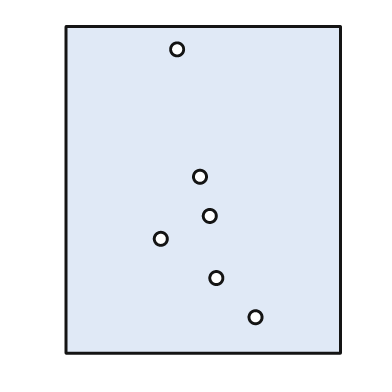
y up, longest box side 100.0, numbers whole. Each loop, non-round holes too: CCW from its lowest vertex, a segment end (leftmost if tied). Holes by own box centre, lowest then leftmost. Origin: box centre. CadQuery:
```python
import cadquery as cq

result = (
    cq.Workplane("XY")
    .moveTo(-42.0, -50.0)
    .lineTo(42.0, -50.0)
    .lineTo(42.0, 50.0)
    .lineTo(-42.0, 50.0)
    .close()
    .moveTo(16.0, -39.0)
    .circle(2.0)
    .moveTo(4.0, -27.0)
    .circle(2.0)
    .moveTo(-13.0, -15.0)
    .circle(2.0)
    .moveTo(2.0, -8.0)
    .circle(2.0)
    .moveTo(-1.0, 4.0)
    .circle(2.0)
    .moveTo(-8.0, 43.0)
    .circle(2.0)
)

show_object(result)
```